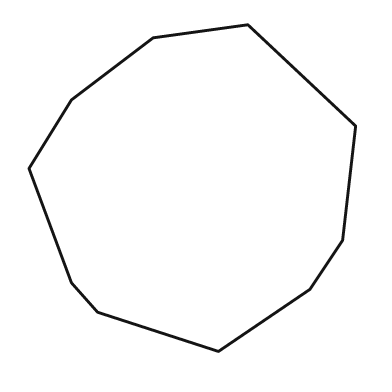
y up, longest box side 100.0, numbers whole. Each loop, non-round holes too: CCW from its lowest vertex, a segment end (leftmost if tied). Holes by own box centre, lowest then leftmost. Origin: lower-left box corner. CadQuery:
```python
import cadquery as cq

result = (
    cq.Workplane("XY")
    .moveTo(58.0, 0.0)
    .lineTo(86.0, 19.0)
    .lineTo(96.0, 34.0)
    .lineTo(100.0, 69.0)
    .lineTo(67.0, 100.0)
    .lineTo(38.0, 96.0)
    .lineTo(13.0, 77.0)
    .lineTo(0.0, 56.0)
    .lineTo(13.0, 21.0)
    .lineTo(21.0, 12.0)
    .close()
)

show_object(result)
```